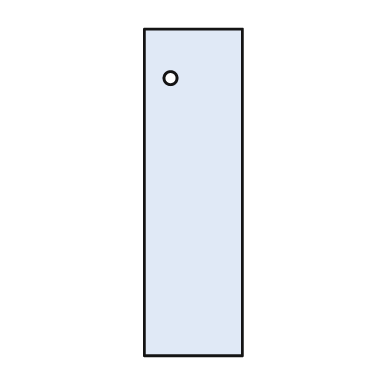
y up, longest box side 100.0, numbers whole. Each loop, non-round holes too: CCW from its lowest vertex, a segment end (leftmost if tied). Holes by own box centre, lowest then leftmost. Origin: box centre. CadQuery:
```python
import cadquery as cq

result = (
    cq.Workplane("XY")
    .moveTo(-15.0, -50.0)
    .lineTo(15.0, -50.0)
    .lineTo(15.0, 50.0)
    .lineTo(-15.0, 50.0)
    .close()
    .moveTo(-7.0, 35.0)
    .circle(2.0)
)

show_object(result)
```